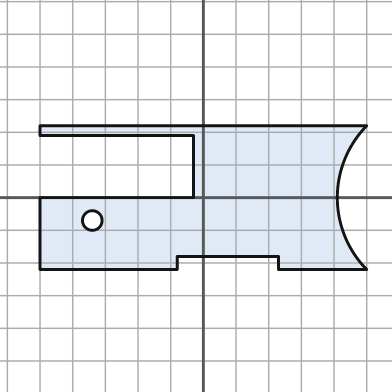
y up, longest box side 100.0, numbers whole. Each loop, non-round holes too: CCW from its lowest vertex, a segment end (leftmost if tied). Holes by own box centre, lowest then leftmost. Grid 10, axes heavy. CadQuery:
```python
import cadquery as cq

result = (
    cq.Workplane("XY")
    .moveTo(-50.0, -22.0)
    .lineTo(-8.0, -22.0)
    .lineTo(-8.0, -18.0)
    .lineTo(23.0, -18.0)
    .lineTo(23.0, -22.0)
    .lineTo(50.0, -22.0)
    .threePointArc((41.0, 0.0), (50.0, 22.0))
    .lineTo(-50.0, 22.0)
    .lineTo(-50.0, 19.0)
    .lineTo(-3.0, 19.0)
    .lineTo(-3.0, 0.0)
    .lineTo(-50.0, 0.0)
    .close()
    .moveTo(-34.0, -7.0)
    .circle(3.0)
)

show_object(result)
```